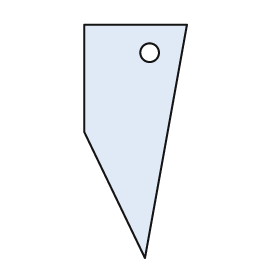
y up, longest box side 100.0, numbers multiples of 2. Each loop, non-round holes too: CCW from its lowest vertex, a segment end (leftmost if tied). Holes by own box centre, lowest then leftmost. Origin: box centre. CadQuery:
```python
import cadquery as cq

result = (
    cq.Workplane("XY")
    .moveTo(4.0, -50.0)
    .lineTo(22.0, 50.0)
    .lineTo(-22.0, 50.0)
    .lineTo(-22.0, 4.0)
    .close()
    .moveTo(6.0, 38.0)
    .circle(4.0)
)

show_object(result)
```